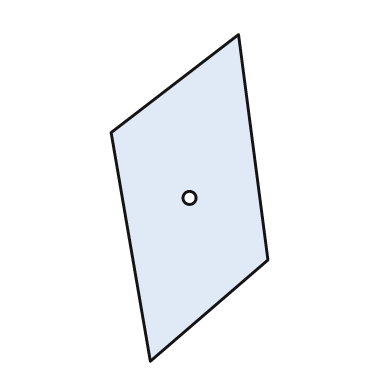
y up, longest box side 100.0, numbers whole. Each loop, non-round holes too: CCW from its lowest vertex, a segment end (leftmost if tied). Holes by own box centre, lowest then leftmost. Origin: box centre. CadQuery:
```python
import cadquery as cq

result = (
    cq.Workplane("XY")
    .moveTo(-12.0, -50.0)
    .lineTo(24.0, -19.0)
    .lineTo(15.0, 50.0)
    .lineTo(-24.0, 20.0)
    .close()
    .moveTo(0.0, 0.0)
    .circle(2.0)
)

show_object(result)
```